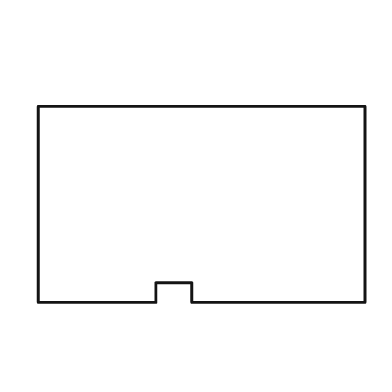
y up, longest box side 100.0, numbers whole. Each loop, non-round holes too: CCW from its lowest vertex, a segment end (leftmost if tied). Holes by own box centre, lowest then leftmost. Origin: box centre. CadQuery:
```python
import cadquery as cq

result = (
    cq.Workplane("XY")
    .moveTo(-50.0, -30.0)
    .lineTo(-14.0, -30.0)
    .lineTo(-14.0, -24.0)
    .lineTo(-3.0, -24.0)
    .lineTo(-3.0, -30.0)
    .lineTo(50.0, -30.0)
    .lineTo(50.0, 30.0)
    .lineTo(-50.0, 30.0)
    .close()
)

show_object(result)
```